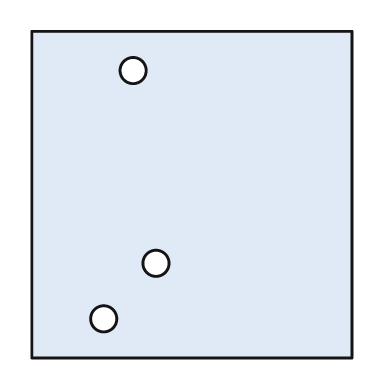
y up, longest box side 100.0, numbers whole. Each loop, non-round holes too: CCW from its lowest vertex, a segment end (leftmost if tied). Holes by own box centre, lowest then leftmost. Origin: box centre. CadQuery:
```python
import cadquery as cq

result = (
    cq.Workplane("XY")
    .moveTo(-49.0, -50.0)
    .lineTo(49.0, -50.0)
    .lineTo(49.0, 50.0)
    .lineTo(-49.0, 50.0)
    .close()
    .moveTo(-27.0, -38.0)
    .circle(4.0)
    .moveTo(-11.0, -21.0)
    .circle(4.0)
    .moveTo(-18.0, 38.0)
    .circle(4.0)
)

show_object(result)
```